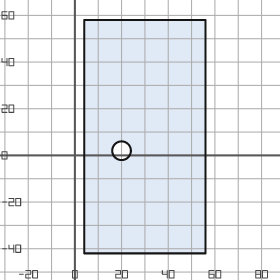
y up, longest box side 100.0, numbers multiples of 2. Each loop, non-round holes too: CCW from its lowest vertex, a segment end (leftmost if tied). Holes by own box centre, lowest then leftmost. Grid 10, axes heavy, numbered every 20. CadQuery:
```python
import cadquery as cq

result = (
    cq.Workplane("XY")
    .moveTo(4.0, -42.0)
    .lineTo(56.0, -42.0)
    .lineTo(56.0, 58.0)
    .lineTo(4.0, 58.0)
    .close()
    .moveTo(20.0, 2.0)
    .circle(4.0)
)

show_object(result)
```